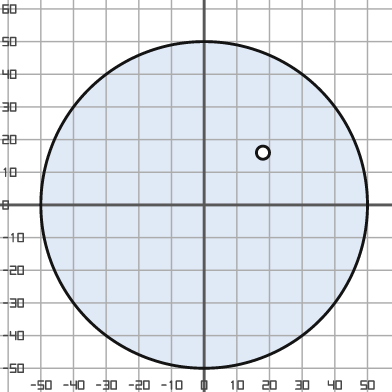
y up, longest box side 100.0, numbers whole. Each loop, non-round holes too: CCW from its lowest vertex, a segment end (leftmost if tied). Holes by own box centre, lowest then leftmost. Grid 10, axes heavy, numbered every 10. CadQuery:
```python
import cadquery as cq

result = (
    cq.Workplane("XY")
    .moveTo(0.0, 0.0)
    .circle(50.0)
    .moveTo(18.0, 16.0)
    .circle(2.0)
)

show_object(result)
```